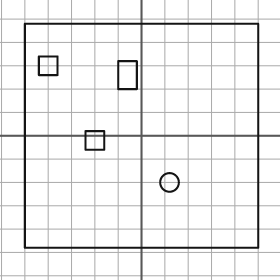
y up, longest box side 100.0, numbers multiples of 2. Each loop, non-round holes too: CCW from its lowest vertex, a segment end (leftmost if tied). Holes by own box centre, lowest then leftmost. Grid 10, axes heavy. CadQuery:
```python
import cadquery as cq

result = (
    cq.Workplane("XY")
    .moveTo(-50.0, -48.0)
    .lineTo(50.0, -48.0)
    .lineTo(50.0, 48.0)
    .lineTo(-50.0, 48.0)
    .close()
    .moveTo(12.0, -20.0)
    .circle(4.0)
    .moveTo(-24.0, -6.0)
    .lineTo(-16.0, -6.0)
    .lineTo(-16.0, 2.0)
    .lineTo(-24.0, 2.0)
    .close()
    .moveTo(-10.0, 20.0)
    .lineTo(-2.0, 20.0)
    .lineTo(-2.0, 32.0)
    .lineTo(-10.0, 32.0)
    .close()
    .moveTo(-44.0, 26.0)
    .lineTo(-36.0, 26.0)
    .lineTo(-36.0, 34.0)
    .lineTo(-44.0, 34.0)
    .close()
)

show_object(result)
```